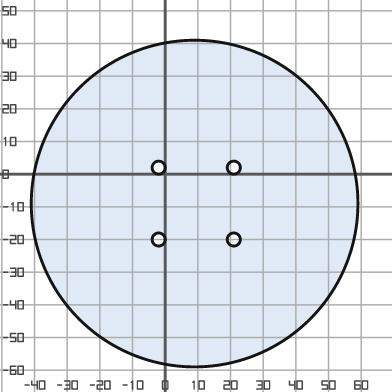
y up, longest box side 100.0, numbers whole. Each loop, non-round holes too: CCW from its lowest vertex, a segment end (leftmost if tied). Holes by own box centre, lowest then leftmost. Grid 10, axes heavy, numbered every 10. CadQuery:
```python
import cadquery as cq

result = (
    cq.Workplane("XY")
    .moveTo(9.0, -9.0)
    .circle(50.0)
    .moveTo(-2.0, -20.0)
    .circle(2.0)
    .moveTo(21.0, -20.0)
    .circle(2.0)
    .moveTo(-2.0, 2.0)
    .circle(2.0)
    .moveTo(21.0, 2.0)
    .circle(2.0)
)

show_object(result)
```